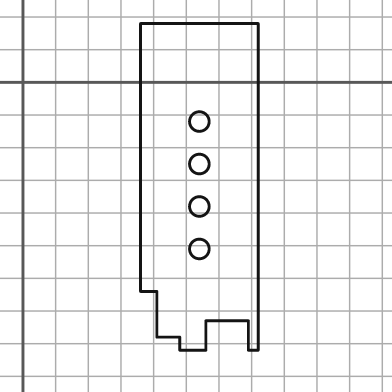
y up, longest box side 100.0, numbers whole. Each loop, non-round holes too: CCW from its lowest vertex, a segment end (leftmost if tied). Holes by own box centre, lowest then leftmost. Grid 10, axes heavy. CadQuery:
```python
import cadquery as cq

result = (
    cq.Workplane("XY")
    .moveTo(48.0, -82.0)
    .lineTo(56.0, -82.0)
    .lineTo(56.0, -73.0)
    .lineTo(69.0, -73.0)
    .lineTo(69.0, -82.0)
    .lineTo(72.0, -82.0)
    .lineTo(72.0, 18.0)
    .lineTo(36.0, 18.0)
    .lineTo(36.0, -64.0)
    .lineTo(41.0, -64.0)
    .lineTo(41.0, -78.0)
    .lineTo(48.0, -78.0)
    .close()
    .moveTo(54.0, -51.0)
    .circle(3.0)
    .moveTo(54.0, -38.0)
    .circle(3.0)
    .moveTo(54.0, -25.0)
    .circle(3.0)
    .moveTo(54.0, -12.0)
    .circle(3.0)
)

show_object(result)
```